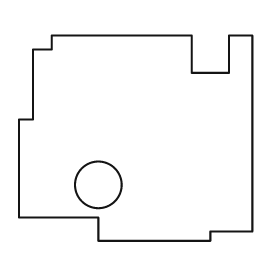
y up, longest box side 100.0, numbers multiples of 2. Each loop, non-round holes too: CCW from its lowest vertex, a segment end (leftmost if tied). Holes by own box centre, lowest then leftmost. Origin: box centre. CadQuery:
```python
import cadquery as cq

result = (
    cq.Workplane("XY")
    .moveTo(-16.0, -44.0)
    .lineTo(32.0, -44.0)
    .lineTo(32.0, -40.0)
    .lineTo(50.0, -40.0)
    .lineTo(50.0, 44.0)
    .lineTo(40.0, 44.0)
    .lineTo(40.0, 28.0)
    .lineTo(24.0, 28.0)
    .lineTo(24.0, 44.0)
    .lineTo(-36.0, 44.0)
    .lineTo(-36.0, 38.0)
    .lineTo(-44.0, 38.0)
    .lineTo(-44.0, 8.0)
    .lineTo(-50.0, 8.0)
    .lineTo(-50.0, -34.0)
    .lineTo(-16.0, -34.0)
    .close()
    .moveTo(-16.0, -20.0)
    .circle(10.0)
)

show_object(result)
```